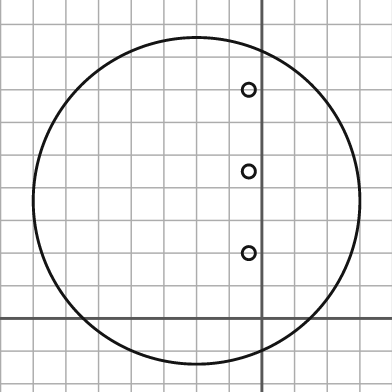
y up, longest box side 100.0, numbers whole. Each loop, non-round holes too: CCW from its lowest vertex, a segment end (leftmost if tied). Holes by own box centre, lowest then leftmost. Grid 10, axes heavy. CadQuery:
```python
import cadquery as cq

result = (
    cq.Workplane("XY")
    .moveTo(-20.0, 36.0)
    .circle(50.0)
    .moveTo(-4.0, 20.0)
    .circle(2.0)
    .moveTo(-4.0, 45.0)
    .circle(2.0)
    .moveTo(-4.0, 70.0)
    .circle(2.0)
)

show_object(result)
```